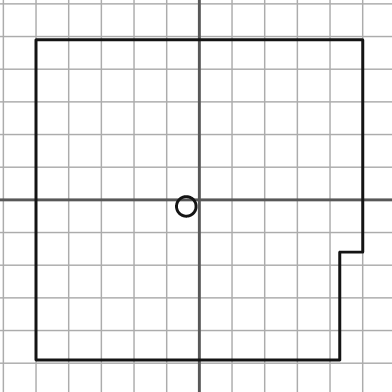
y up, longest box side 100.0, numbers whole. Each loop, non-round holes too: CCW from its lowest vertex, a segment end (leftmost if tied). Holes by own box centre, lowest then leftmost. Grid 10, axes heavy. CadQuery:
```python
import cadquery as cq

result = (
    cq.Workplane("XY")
    .moveTo(-50.0, -49.0)
    .lineTo(43.0, -49.0)
    .lineTo(43.0, -16.0)
    .lineTo(50.0, -16.0)
    .lineTo(50.0, 49.0)
    .lineTo(-50.0, 49.0)
    .close()
    .moveTo(-4.0, -2.0)
    .circle(3.0)
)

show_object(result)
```